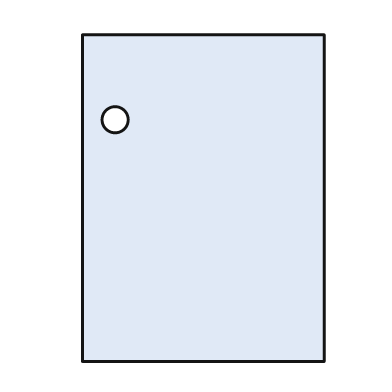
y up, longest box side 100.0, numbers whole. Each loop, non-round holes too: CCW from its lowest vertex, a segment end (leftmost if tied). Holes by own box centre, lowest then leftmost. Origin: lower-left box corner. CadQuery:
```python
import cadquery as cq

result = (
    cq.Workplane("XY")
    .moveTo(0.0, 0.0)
    .lineTo(74.0, 0.0)
    .lineTo(74.0, 100.0)
    .lineTo(0.0, 100.0)
    .close()
    .moveTo(10.0, 74.0)
    .circle(4.0)
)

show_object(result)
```